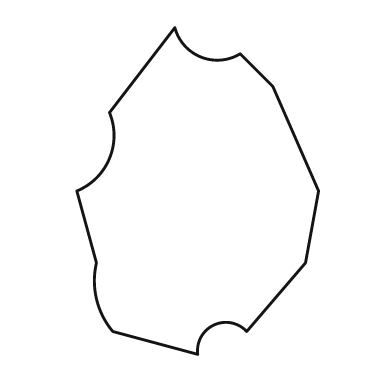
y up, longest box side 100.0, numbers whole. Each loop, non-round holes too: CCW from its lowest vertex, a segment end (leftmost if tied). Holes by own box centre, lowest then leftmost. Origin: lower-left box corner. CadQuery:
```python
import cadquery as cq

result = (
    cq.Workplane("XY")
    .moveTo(37.0, 0.0)
    .threePointArc((42.0, 9.0), (52.0, 7.0))
    .lineTo(70.0, 28.0)
    .lineTo(74.0, 50.0)
    .lineTo(60.0, 82.0)
    .lineTo(50.0, 92.0)
    .threePointArc((38.0, 91.0), (30.0, 100.0))
    .lineTo(10.0, 74.0)
    .threePointArc((10.0, 60.0), (0.0, 50.0))
    .lineTo(6.0, 28.0)
    .threePointArc((6.0, 17.0), (11.0, 7.0))
    .close()
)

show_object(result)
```